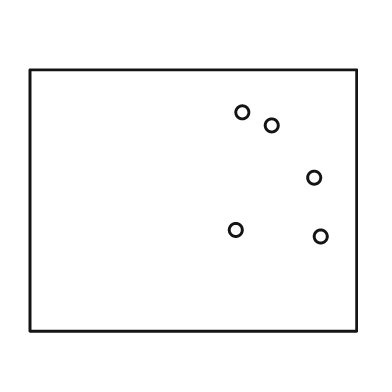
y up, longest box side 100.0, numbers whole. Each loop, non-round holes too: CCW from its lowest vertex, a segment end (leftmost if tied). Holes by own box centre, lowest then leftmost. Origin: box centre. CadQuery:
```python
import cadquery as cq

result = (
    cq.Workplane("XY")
    .moveTo(-50.0, -40.0)
    .lineTo(50.0, -40.0)
    .lineTo(50.0, 40.0)
    .lineTo(-50.0, 40.0)
    .close()
    .moveTo(39.0, -11.0)
    .circle(2.0)
    .moveTo(13.0, -9.0)
    .circle(2.0)
    .moveTo(37.0, 7.0)
    .circle(2.0)
    .moveTo(24.0, 23.0)
    .circle(2.0)
    .moveTo(15.0, 27.0)
    .circle(2.0)
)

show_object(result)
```